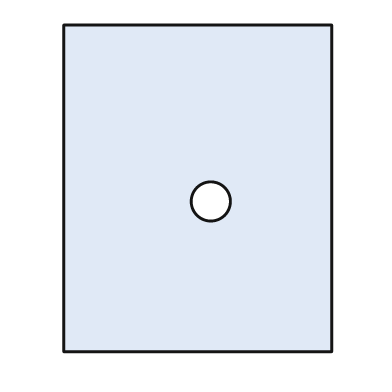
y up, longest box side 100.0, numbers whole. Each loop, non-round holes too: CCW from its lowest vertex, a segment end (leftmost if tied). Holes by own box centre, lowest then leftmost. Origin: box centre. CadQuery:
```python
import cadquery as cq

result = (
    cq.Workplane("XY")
    .moveTo(-41.0, -50.0)
    .lineTo(41.0, -50.0)
    .lineTo(41.0, 50.0)
    .lineTo(-41.0, 50.0)
    .close()
    .moveTo(4.0, -4.0)
    .circle(6.0)
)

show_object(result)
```